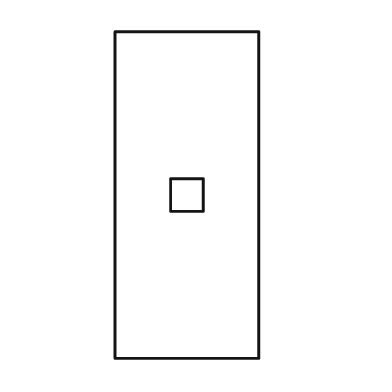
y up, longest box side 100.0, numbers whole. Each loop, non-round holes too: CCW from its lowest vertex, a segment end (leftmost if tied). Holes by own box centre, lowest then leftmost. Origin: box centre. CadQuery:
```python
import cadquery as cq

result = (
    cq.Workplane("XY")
    .moveTo(-22.0, -50.0)
    .lineTo(22.0, -50.0)
    .lineTo(22.0, 50.0)
    .lineTo(-22.0, 50.0)
    .close()
    .moveTo(-5.0, -5.0)
    .lineTo(5.0, -5.0)
    .lineTo(5.0, 5.0)
    .lineTo(-5.0, 5.0)
    .close()
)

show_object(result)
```